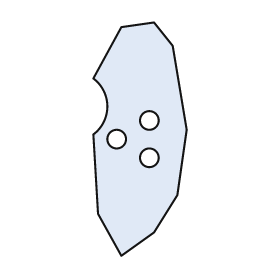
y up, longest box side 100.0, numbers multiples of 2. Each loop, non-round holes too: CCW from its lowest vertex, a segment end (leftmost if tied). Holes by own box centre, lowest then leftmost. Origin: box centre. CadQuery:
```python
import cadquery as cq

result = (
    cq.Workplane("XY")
    .moveTo(-8.0, -50.0)
    .lineTo(6.0, -40.0)
    .lineTo(16.0, -24.0)
    .lineTo(20.0, 4.0)
    .lineTo(14.0, 40.0)
    .lineTo(6.0, 50.0)
    .lineTo(-8.0, 48.0)
    .lineTo(-20.0, 26.0)
    .threePointArc((-14.0, 14.0), (-20.0, 2.0))
    .lineTo(-18.0, -32.0)
    .close()
    .moveTo(4.0, -8.0)
    .circle(4.0)
    .moveTo(-10.0, 0.0)
    .circle(4.0)
    .moveTo(4.0, 8.0)
    .circle(4.0)
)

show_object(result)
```